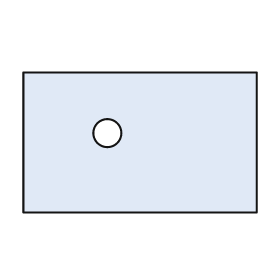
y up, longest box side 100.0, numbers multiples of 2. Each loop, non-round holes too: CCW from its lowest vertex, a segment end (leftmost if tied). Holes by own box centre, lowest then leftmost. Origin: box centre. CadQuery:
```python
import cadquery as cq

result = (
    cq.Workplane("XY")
    .moveTo(-50.0, -30.0)
    .lineTo(50.0, -30.0)
    .lineTo(50.0, 30.0)
    .lineTo(-50.0, 30.0)
    .close()
    .moveTo(-14.0, 4.0)
    .circle(6.0)
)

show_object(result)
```